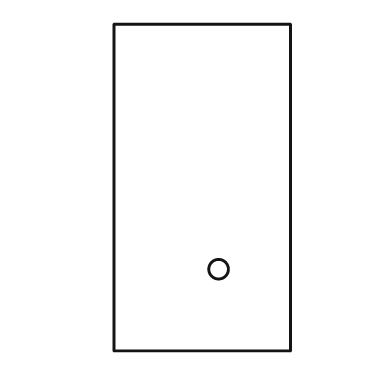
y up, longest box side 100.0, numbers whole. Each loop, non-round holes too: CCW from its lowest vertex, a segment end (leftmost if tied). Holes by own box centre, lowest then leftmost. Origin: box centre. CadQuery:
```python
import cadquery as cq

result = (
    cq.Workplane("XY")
    .moveTo(-27.0, -50.0)
    .lineTo(27.0, -50.0)
    .lineTo(27.0, 50.0)
    .lineTo(-27.0, 50.0)
    .close()
    .moveTo(5.0, -25.0)
    .circle(3.0)
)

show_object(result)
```